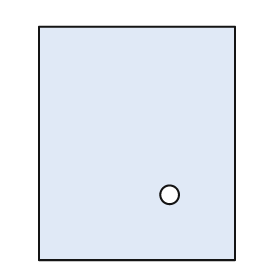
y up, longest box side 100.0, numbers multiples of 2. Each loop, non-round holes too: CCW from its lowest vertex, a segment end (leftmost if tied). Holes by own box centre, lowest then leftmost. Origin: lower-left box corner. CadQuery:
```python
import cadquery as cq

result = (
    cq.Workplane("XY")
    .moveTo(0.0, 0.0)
    .lineTo(84.0, 0.0)
    .lineTo(84.0, 100.0)
    .lineTo(0.0, 100.0)
    .close()
    .moveTo(56.0, 28.0)
    .circle(4.0)
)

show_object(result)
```